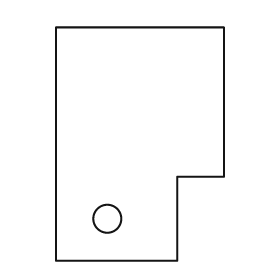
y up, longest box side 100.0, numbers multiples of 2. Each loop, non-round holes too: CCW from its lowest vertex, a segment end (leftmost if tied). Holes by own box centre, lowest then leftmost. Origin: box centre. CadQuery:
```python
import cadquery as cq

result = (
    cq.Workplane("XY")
    .moveTo(-36.0, -50.0)
    .lineTo(16.0, -50.0)
    .lineTo(16.0, -14.0)
    .lineTo(36.0, -14.0)
    .lineTo(36.0, 50.0)
    .lineTo(-36.0, 50.0)
    .close()
    .moveTo(-14.0, -32.0)
    .circle(6.0)
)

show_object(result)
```